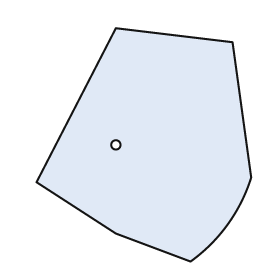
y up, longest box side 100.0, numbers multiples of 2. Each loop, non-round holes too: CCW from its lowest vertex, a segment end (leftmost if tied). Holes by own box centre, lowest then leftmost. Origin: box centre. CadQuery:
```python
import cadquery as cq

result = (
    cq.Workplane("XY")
    .moveTo(20.0, -50.0)
    .threePointArc((36.0, -34.0), (46.0, -14.0))
    .lineTo(38.0, 44.0)
    .lineTo(-12.0, 50.0)
    .lineTo(-46.0, -16.0)
    .lineTo(-12.0, -38.0)
    .close()
    .moveTo(-12.0, 0.0)
    .circle(2.0)
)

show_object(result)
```